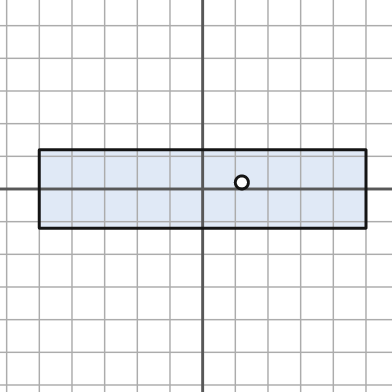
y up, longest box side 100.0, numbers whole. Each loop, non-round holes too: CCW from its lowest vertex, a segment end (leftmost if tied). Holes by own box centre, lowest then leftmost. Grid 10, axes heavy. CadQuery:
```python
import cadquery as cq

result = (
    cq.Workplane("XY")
    .moveTo(-50.0, -12.0)
    .lineTo(50.0, -12.0)
    .lineTo(50.0, 12.0)
    .lineTo(-50.0, 12.0)
    .close()
    .moveTo(12.0, 2.0)
    .circle(2.0)
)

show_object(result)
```